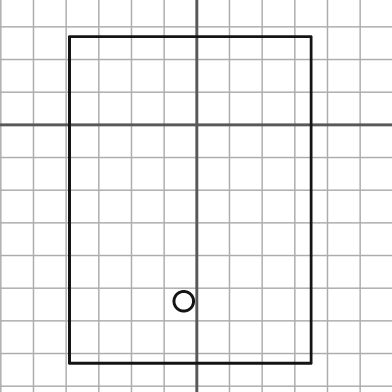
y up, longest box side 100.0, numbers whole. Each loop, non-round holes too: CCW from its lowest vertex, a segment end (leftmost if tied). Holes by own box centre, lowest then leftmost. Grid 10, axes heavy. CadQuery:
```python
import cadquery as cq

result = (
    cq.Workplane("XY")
    .moveTo(-39.0, -73.0)
    .lineTo(35.0, -73.0)
    .lineTo(35.0, 27.0)
    .lineTo(-39.0, 27.0)
    .close()
    .moveTo(-4.0, -54.0)
    .circle(3.0)
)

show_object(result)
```